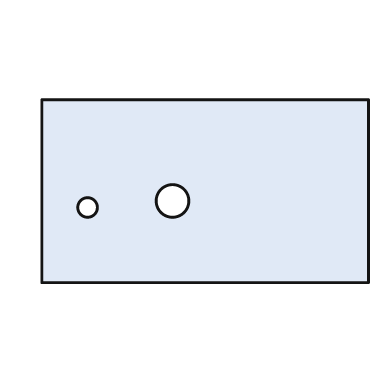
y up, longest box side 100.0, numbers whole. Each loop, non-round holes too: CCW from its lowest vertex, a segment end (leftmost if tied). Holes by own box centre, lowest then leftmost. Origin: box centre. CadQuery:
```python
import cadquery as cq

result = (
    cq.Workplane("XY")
    .moveTo(-50.0, -28.0)
    .lineTo(50.0, -28.0)
    .lineTo(50.0, 28.0)
    .lineTo(-50.0, 28.0)
    .close()
    .moveTo(-36.0, -5.0)
    .circle(3.0)
    .moveTo(-10.0, -3.0)
    .circle(5.0)
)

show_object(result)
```